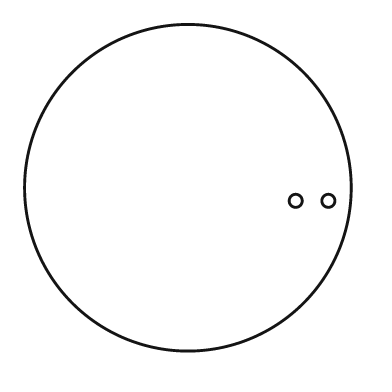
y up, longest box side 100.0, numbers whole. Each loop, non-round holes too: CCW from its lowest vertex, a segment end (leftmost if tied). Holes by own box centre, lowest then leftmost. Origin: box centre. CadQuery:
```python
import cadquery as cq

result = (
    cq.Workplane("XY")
    .moveTo(0.0, 0.0)
    .circle(50.0)
    .moveTo(33.0, -4.0)
    .circle(2.0)
    .moveTo(43.0, -4.0)
    .circle(2.0)
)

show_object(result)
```